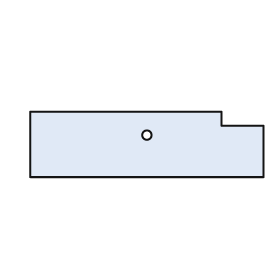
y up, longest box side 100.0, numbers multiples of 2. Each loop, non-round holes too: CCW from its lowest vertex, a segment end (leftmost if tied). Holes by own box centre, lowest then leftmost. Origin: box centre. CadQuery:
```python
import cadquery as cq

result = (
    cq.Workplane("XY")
    .moveTo(-50.0, -14.0)
    .lineTo(50.0, -14.0)
    .lineTo(50.0, 8.0)
    .lineTo(32.0, 8.0)
    .lineTo(32.0, 14.0)
    .lineTo(-50.0, 14.0)
    .close()
    .moveTo(0.0, 4.0)
    .circle(2.0)
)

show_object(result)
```